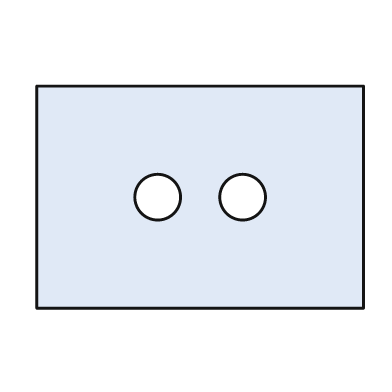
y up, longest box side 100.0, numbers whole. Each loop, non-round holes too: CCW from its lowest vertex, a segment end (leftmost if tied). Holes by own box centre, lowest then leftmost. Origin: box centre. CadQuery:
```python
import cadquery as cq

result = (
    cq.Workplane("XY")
    .moveTo(-50.0, -34.0)
    .lineTo(50.0, -34.0)
    .lineTo(50.0, 34.0)
    .lineTo(-50.0, 34.0)
    .close()
    .moveTo(-13.0, 0.0)
    .circle(7.0)
    .moveTo(13.0, 0.0)
    .circle(7.0)
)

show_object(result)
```